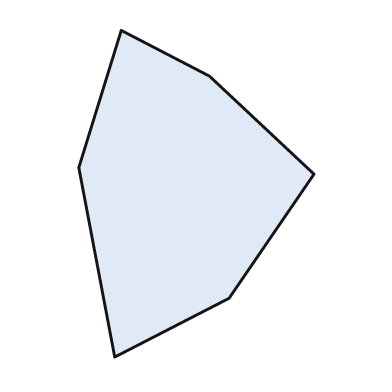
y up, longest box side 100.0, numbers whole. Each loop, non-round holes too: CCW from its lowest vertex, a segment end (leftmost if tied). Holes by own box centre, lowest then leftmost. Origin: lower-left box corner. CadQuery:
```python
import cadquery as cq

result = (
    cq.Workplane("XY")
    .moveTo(11.0, 0.0)
    .lineTo(46.0, 18.0)
    .lineTo(72.0, 56.0)
    .lineTo(40.0, 86.0)
    .lineTo(13.0, 100.0)
    .lineTo(0.0, 58.0)
    .close()
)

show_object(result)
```